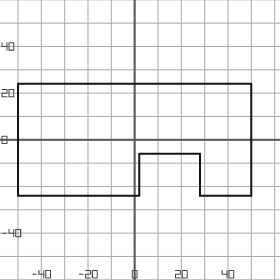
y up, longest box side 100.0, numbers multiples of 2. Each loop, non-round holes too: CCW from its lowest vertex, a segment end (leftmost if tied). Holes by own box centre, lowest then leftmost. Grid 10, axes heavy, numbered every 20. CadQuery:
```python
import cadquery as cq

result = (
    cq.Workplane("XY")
    .moveTo(-50.0, -24.0)
    .lineTo(2.0, -24.0)
    .lineTo(2.0, -6.0)
    .lineTo(28.0, -6.0)
    .lineTo(28.0, -24.0)
    .lineTo(50.0, -24.0)
    .lineTo(50.0, 24.0)
    .lineTo(-50.0, 24.0)
    .close()
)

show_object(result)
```